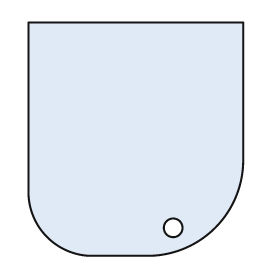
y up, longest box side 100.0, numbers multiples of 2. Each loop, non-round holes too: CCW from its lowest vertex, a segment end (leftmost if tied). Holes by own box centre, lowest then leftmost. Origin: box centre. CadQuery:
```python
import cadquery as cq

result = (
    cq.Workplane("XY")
    .moveTo(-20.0, -50.0)
    .lineTo(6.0, -50.0)
    .threePointArc((34.0, -38.0), (46.0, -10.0))
    .lineTo(46.0, 50.0)
    .lineTo(-46.0, 50.0)
    .lineTo(-46.0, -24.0)
    .threePointArc((-38.0, -42.0), (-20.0, -50.0))
    .close()
    .moveTo(16.0, -38.0)
    .circle(4.0)
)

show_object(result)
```